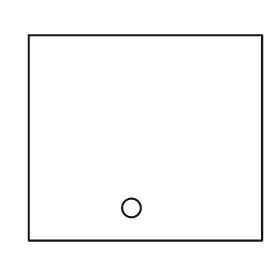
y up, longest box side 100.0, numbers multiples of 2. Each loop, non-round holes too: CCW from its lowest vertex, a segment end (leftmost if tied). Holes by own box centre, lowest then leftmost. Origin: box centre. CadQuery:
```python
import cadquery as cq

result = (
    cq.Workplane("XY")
    .moveTo(-50.0, -44.0)
    .lineTo(50.0, -44.0)
    .lineTo(50.0, 44.0)
    .lineTo(-50.0, 44.0)
    .close()
    .moveTo(-6.0, -30.0)
    .circle(4.0)
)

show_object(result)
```